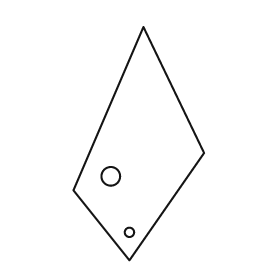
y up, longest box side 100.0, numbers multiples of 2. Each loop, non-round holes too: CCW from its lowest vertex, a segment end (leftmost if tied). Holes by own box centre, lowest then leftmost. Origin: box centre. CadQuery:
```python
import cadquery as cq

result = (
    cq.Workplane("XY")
    .moveTo(-4.0, -50.0)
    .lineTo(28.0, -4.0)
    .lineTo(2.0, 50.0)
    .lineTo(-28.0, -20.0)
    .close()
    .moveTo(-4.0, -38.0)
    .circle(2.0)
    .moveTo(-12.0, -14.0)
    .circle(4.0)
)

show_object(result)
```